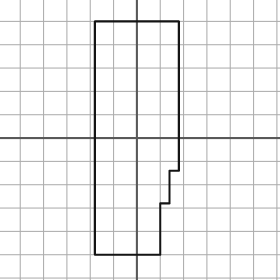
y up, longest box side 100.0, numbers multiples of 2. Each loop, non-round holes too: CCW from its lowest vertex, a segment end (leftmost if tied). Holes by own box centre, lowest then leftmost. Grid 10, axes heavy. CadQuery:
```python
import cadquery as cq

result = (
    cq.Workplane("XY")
    .moveTo(-18.0, -50.0)
    .lineTo(10.0, -50.0)
    .lineTo(10.0, -28.0)
    .lineTo(14.0, -28.0)
    .lineTo(14.0, -14.0)
    .lineTo(18.0, -14.0)
    .lineTo(18.0, 50.0)
    .lineTo(-18.0, 50.0)
    .close()
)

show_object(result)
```